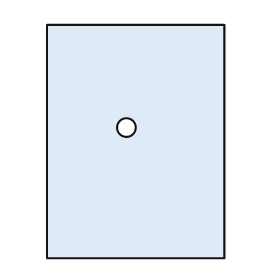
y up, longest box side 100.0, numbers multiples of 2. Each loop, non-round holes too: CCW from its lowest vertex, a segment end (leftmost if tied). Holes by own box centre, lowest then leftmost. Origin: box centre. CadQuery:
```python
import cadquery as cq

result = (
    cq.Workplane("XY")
    .moveTo(-38.0, -50.0)
    .lineTo(38.0, -50.0)
    .lineTo(38.0, 50.0)
    .lineTo(-38.0, 50.0)
    .close()
    .moveTo(-4.0, 6.0)
    .circle(4.0)
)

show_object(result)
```